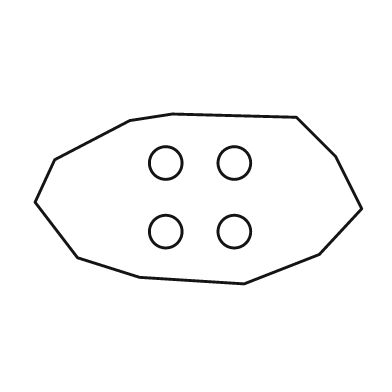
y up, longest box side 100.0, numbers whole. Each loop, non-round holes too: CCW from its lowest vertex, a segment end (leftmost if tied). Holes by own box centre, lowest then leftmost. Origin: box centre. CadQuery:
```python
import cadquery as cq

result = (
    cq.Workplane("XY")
    .moveTo(14.0, -26.0)
    .lineTo(37.0, -17.0)
    .lineTo(50.0, -3.0)
    .lineTo(42.0, 13.0)
    .lineTo(30.0, 25.0)
    .lineTo(-8.0, 26.0)
    .lineTo(-21.0, 24.0)
    .lineTo(-44.0, 12.0)
    .lineTo(-50.0, -1.0)
    .lineTo(-37.0, -18.0)
    .lineTo(-18.0, -24.0)
    .close()
    .moveTo(-10.0, -10.0)
    .circle(5.0)
    .moveTo(11.0, -10.0)
    .circle(5.0)
    .moveTo(-10.0, 11.0)
    .circle(5.0)
    .moveTo(11.0, 11.0)
    .circle(5.0)
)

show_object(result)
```